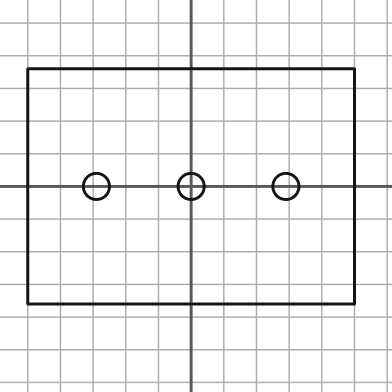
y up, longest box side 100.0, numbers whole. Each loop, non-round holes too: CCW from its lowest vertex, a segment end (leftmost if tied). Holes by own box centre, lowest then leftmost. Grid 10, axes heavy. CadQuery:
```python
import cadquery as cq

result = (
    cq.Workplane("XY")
    .moveTo(-50.0, -36.0)
    .lineTo(50.0, -36.0)
    .lineTo(50.0, 36.0)
    .lineTo(-50.0, 36.0)
    .close()
    .moveTo(-29.0, 0.0)
    .circle(4.0)
    .moveTo(0.0, 0.0)
    .circle(4.0)
    .moveTo(29.0, 0.0)
    .circle(4.0)
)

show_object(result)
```